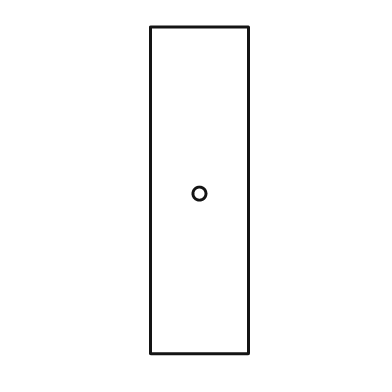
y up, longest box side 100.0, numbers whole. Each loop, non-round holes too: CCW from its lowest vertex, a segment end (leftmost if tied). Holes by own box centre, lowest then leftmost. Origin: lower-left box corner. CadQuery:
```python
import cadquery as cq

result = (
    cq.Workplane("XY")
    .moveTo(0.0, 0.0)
    .lineTo(30.0, 0.0)
    .lineTo(30.0, 100.0)
    .lineTo(0.0, 100.0)
    .close()
    .moveTo(15.0, 49.0)
    .circle(2.0)
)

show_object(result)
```